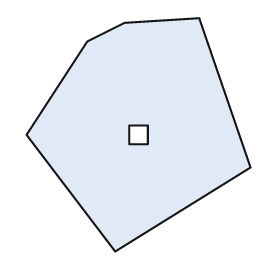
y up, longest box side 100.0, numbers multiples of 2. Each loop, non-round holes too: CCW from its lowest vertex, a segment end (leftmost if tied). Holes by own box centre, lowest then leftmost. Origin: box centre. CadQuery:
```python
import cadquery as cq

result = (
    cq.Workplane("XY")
    .moveTo(-10.0, -50.0)
    .lineTo(48.0, -14.0)
    .lineTo(26.0, 50.0)
    .lineTo(-6.0, 48.0)
    .lineTo(-22.0, 40.0)
    .lineTo(-48.0, 0.0)
    .close()
    .moveTo(-4.0, -4.0)
    .lineTo(4.0, -4.0)
    .lineTo(4.0, 4.0)
    .lineTo(-4.0, 4.0)
    .close()
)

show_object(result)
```